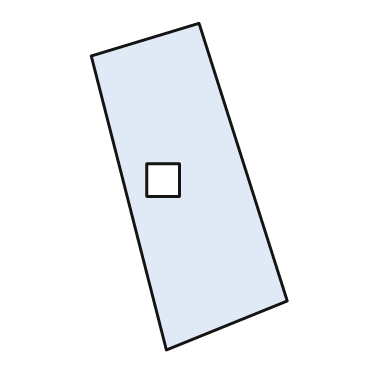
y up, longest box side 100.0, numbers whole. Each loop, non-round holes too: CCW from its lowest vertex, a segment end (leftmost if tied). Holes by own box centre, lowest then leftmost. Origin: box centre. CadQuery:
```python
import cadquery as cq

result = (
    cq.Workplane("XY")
    .moveTo(-7.0, -50.0)
    .lineTo(30.0, -35.0)
    .lineTo(3.0, 50.0)
    .lineTo(-30.0, 40.0)
    .close()
    .moveTo(-13.0, -3.0)
    .lineTo(-3.0, -3.0)
    .lineTo(-3.0, 7.0)
    .lineTo(-13.0, 7.0)
    .close()
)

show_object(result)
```